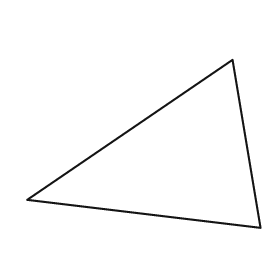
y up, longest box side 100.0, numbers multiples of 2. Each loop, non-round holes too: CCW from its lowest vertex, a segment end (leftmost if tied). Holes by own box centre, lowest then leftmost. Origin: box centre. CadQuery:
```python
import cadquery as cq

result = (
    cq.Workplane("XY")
    .moveTo(50.0, -36.0)
    .lineTo(38.0, 36.0)
    .lineTo(-50.0, -24.0)
    .close()
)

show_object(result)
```